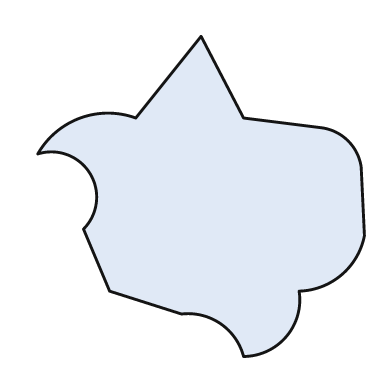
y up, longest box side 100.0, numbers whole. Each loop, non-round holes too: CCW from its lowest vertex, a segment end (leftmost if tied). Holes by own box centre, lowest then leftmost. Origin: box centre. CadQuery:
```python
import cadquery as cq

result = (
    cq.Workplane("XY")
    .moveTo(13.0, -49.0)
    .threePointArc((26.0, -43.0), (30.0, -29.0))
    .threePointArc((43.0, -24.0), (50.0, -12.0))
    .lineTo(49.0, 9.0)
    .threePointArc((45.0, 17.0), (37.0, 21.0))
    .lineTo(13.0, 24.0)
    .lineTo(0.0, 49.0)
    .lineTo(-20.0, 24.0)
    .threePointArc((-37.0, 24.0), (-50.0, 13.0))
    .threePointArc((-34.0, 7.0), (-36.0, -10.0))
    .lineTo(-28.0, -29.0)
    .lineTo(-6.0, -36.0)
    .threePointArc((6.0, -39.0), (13.0, -49.0))
    .close()
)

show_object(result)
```